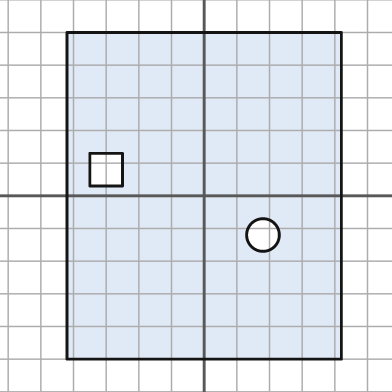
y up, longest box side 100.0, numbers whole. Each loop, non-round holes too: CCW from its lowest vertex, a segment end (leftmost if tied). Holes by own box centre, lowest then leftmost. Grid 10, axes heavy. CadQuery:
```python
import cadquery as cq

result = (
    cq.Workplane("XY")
    .moveTo(-42.0, -50.0)
    .lineTo(42.0, -50.0)
    .lineTo(42.0, 50.0)
    .lineTo(-42.0, 50.0)
    .close()
    .moveTo(18.0, -12.0)
    .circle(5.0)
    .moveTo(-35.0, 3.0)
    .lineTo(-25.0, 3.0)
    .lineTo(-25.0, 13.0)
    .lineTo(-35.0, 13.0)
    .close()
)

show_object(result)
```